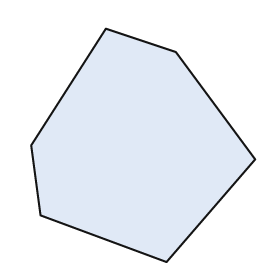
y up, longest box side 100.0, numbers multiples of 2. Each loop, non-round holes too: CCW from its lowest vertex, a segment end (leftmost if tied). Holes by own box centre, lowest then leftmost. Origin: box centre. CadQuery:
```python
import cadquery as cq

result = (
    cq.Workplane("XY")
    .moveTo(10.0, -50.0)
    .lineTo(48.0, -6.0)
    .lineTo(14.0, 40.0)
    .lineTo(-16.0, 50.0)
    .lineTo(-48.0, 0.0)
    .lineTo(-44.0, -30.0)
    .close()
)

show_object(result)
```